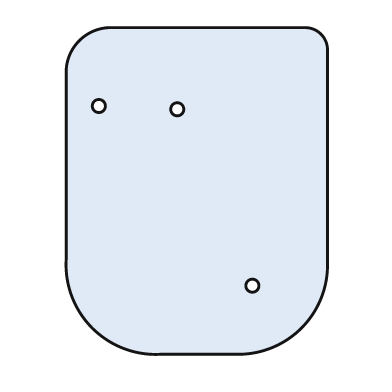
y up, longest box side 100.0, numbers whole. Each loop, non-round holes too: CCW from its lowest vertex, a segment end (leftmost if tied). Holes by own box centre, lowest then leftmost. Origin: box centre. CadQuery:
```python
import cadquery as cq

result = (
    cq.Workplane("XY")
    .moveTo(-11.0, -50.0)
    .lineTo(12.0, -50.0)
    .threePointArc((32.0, -42.0), (40.0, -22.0))
    .lineTo(40.0, 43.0)
    .threePointArc((38.0, 48.0), (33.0, 50.0))
    .lineTo(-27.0, 50.0)
    .threePointArc((-36.0, 46.0), (-40.0, 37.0))
    .lineTo(-40.0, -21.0)
    .threePointArc((-32.0, -42.0), (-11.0, -50.0))
    .close()
    .moveTo(17.0, -29.0)
    .circle(2.0)
    .moveTo(-6.0, 25.0)
    .circle(2.0)
    .moveTo(-30.0, 26.0)
    .circle(2.0)
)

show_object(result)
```